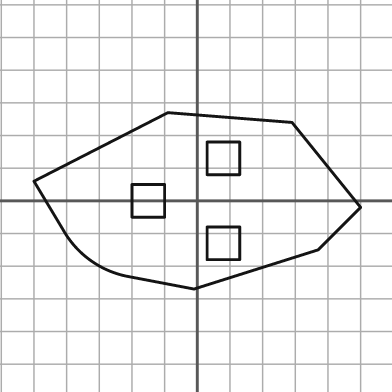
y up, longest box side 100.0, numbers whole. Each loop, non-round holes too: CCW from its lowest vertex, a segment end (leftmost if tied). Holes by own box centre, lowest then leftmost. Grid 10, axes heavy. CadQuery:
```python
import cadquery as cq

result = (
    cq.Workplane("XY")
    .moveTo(-1.0, -27.0)
    .lineTo(37.0, -15.0)
    .lineTo(50.0, -2.0)
    .lineTo(29.0, 24.0)
    .lineTo(-9.0, 27.0)
    .lineTo(-50.0, 6.0)
    .lineTo(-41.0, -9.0)
    .threePointArc((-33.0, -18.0), (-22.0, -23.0))
    .close()
    .moveTo(3.0, -18.0)
    .lineTo(13.0, -18.0)
    .lineTo(13.0, -8.0)
    .lineTo(3.0, -8.0)
    .close()
    .moveTo(-20.0, -5.0)
    .lineTo(-10.0, -5.0)
    .lineTo(-10.0, 5.0)
    .lineTo(-20.0, 5.0)
    .close()
    .moveTo(3.0, 8.0)
    .lineTo(13.0, 8.0)
    .lineTo(13.0, 18.0)
    .lineTo(3.0, 18.0)
    .close()
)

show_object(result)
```